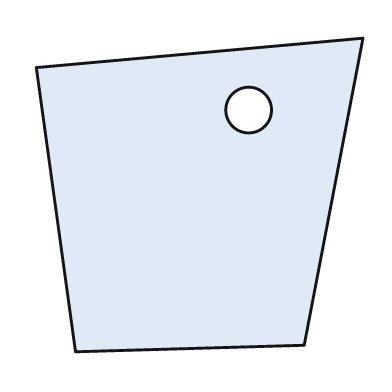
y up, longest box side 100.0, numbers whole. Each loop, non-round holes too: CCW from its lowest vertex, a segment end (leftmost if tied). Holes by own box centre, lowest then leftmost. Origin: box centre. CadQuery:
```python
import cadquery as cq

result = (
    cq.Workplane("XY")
    .moveTo(-38.0, -48.0)
    .lineTo(32.0, -46.0)
    .lineTo(50.0, 48.0)
    .lineTo(-50.0, 39.0)
    .close()
    .moveTo(15.0, 26.0)
    .circle(7.0)
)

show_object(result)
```